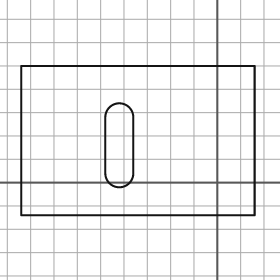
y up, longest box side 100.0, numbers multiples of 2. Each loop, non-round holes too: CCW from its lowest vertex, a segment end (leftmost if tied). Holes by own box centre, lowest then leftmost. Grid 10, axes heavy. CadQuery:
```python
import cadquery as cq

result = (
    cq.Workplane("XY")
    .moveTo(-84.0, -14.0)
    .lineTo(16.0, -14.0)
    .lineTo(16.0, 50.0)
    .lineTo(-84.0, 50.0)
    .close()
    .moveTo(-48.0, 4.0)
    .threePointArc((-42.0, -2.0), (-36.0, 4.0))
    .lineTo(-36.0, 28.0)
    .threePointArc((-42.0, 34.0), (-48.0, 28.0))
    .close()
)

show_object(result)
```